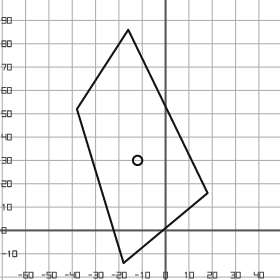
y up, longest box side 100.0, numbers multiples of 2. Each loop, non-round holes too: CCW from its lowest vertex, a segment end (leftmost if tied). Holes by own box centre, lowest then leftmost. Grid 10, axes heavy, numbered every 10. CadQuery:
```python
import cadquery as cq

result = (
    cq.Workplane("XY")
    .moveTo(-18.0, -14.0)
    .lineTo(18.0, 16.0)
    .lineTo(-16.0, 86.0)
    .lineTo(-38.0, 52.0)
    .close()
    .moveTo(-12.0, 30.0)
    .circle(2.0)
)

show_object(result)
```